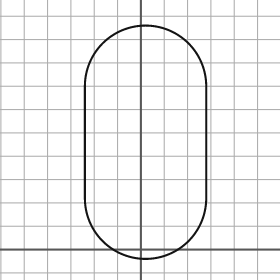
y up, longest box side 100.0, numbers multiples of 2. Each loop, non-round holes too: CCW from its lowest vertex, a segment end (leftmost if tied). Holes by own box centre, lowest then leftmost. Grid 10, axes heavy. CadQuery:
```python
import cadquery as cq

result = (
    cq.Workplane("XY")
    .moveTo(-24.0, 22.0)
    .threePointArc((2.0, -4.0), (28.0, 22.0))
    .lineTo(28.0, 70.0)
    .threePointArc((2.0, 96.0), (-24.0, 70.0))
    .close()
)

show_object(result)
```